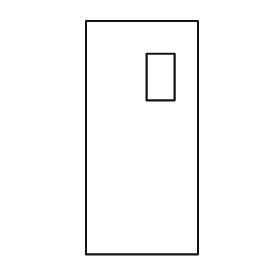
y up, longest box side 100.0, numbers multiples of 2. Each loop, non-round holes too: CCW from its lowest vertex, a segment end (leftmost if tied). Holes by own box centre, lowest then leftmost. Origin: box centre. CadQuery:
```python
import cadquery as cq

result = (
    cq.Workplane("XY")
    .moveTo(-24.0, -50.0)
    .lineTo(24.0, -50.0)
    .lineTo(24.0, 50.0)
    .lineTo(-24.0, 50.0)
    .close()
    .moveTo(2.0, 16.0)
    .lineTo(14.0, 16.0)
    .lineTo(14.0, 36.0)
    .lineTo(2.0, 36.0)
    .close()
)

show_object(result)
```